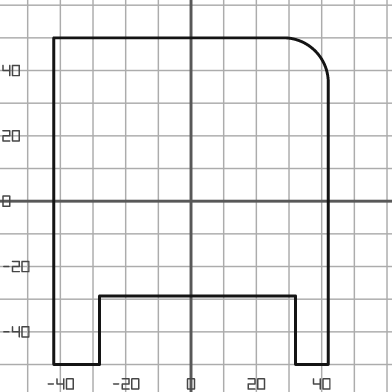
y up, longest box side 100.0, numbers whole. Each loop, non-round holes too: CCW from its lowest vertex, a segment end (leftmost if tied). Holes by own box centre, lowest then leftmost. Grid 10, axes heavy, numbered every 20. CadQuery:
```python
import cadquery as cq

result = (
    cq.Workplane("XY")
    .moveTo(-42.0, -50.0)
    .lineTo(-28.0, -50.0)
    .lineTo(-28.0, -29.0)
    .lineTo(32.0, -29.0)
    .lineTo(32.0, -50.0)
    .lineTo(42.0, -50.0)
    .lineTo(42.0, 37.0)
    .threePointArc((38.0, 46.0), (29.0, 50.0))
    .lineTo(-42.0, 50.0)
    .close()
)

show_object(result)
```